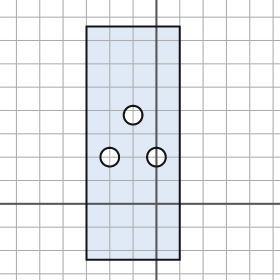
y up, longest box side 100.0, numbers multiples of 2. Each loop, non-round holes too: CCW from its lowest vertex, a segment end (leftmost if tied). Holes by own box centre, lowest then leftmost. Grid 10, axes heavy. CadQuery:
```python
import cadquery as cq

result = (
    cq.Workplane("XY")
    .moveTo(-30.0, -24.0)
    .lineTo(10.0, -24.0)
    .lineTo(10.0, 76.0)
    .lineTo(-30.0, 76.0)
    .close()
    .moveTo(-20.0, 20.0)
    .circle(4.0)
    .moveTo(0.0, 20.0)
    .circle(4.0)
    .moveTo(-10.0, 38.0)
    .circle(4.0)
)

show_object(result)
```